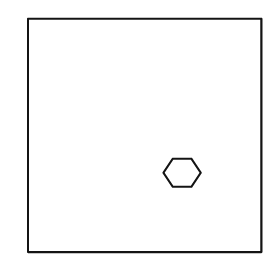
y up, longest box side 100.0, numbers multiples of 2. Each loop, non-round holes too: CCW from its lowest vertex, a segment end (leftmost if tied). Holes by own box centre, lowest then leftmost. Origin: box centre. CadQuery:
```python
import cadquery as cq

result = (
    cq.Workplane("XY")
    .moveTo(-50.0, -50.0)
    .lineTo(50.0, -50.0)
    .lineTo(50.0, 50.0)
    .lineTo(-50.0, 50.0)
    .close()
    .moveTo(12.0, -22.0)
    .lineTo(20.0, -22.0)
    .lineTo(24.0, -16.0)
    .lineTo(20.0, -10.0)
    .lineTo(12.0, -10.0)
    .lineTo(8.0, -16.0)
    .close()
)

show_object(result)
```